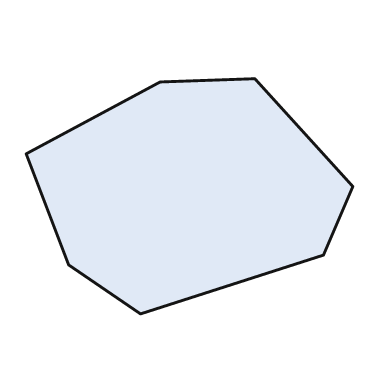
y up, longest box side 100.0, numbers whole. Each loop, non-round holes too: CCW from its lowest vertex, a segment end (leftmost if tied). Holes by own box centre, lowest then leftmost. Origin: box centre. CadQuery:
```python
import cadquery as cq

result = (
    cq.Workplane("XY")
    .moveTo(-15.0, -36.0)
    .lineTo(41.0, -18.0)
    .lineTo(50.0, 3.0)
    .lineTo(20.0, 36.0)
    .lineTo(-9.0, 35.0)
    .lineTo(-50.0, 13.0)
    .lineTo(-37.0, -21.0)
    .close()
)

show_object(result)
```